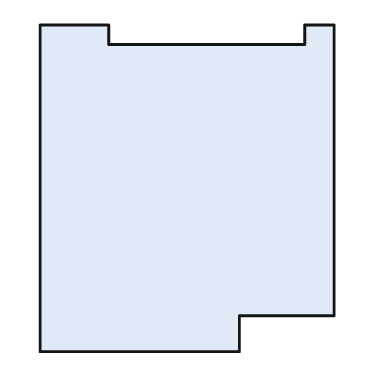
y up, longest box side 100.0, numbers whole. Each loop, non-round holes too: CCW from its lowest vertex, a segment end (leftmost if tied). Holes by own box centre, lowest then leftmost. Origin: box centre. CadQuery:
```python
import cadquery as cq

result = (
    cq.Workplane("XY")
    .moveTo(-45.0, -50.0)
    .lineTo(16.0, -50.0)
    .lineTo(16.0, -39.0)
    .lineTo(45.0, -39.0)
    .lineTo(45.0, 50.0)
    .lineTo(36.0, 50.0)
    .lineTo(36.0, 44.0)
    .lineTo(-24.0, 44.0)
    .lineTo(-24.0, 50.0)
    .lineTo(-45.0, 50.0)
    .close()
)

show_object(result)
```